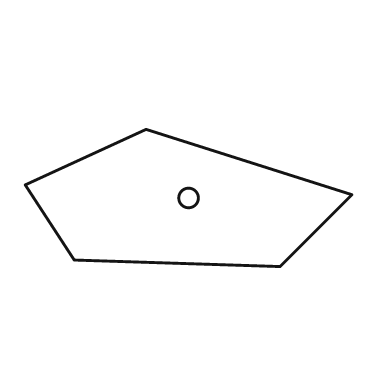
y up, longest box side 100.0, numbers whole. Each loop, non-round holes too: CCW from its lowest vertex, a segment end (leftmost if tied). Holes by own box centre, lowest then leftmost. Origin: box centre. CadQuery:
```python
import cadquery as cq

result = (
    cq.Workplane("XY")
    .moveTo(28.0, -21.0)
    .lineTo(50.0, 1.0)
    .lineTo(-13.0, 21.0)
    .lineTo(-50.0, 4.0)
    .lineTo(-35.0, -19.0)
    .close()
    .moveTo(0.0, 0.0)
    .circle(3.0)
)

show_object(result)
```